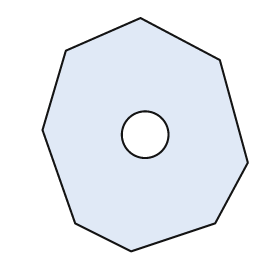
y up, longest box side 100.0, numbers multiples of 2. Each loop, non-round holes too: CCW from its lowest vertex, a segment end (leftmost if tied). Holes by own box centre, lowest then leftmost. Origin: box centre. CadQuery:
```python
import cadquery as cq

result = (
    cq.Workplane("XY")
    .moveTo(-6.0, -50.0)
    .lineTo(30.0, -38.0)
    .lineTo(44.0, -12.0)
    .lineTo(32.0, 32.0)
    .lineTo(-2.0, 50.0)
    .lineTo(-34.0, 36.0)
    .lineTo(-44.0, 2.0)
    .lineTo(-30.0, -38.0)
    .close()
    .moveTo(0.0, 0.0)
    .circle(10.0)
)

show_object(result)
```